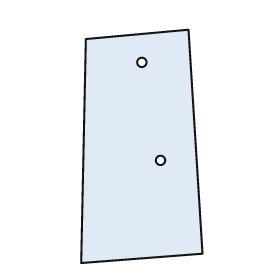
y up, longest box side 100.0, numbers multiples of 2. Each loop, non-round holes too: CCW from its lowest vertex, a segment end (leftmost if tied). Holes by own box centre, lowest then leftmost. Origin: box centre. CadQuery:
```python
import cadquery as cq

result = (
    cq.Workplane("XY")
    .moveTo(-26.0, -50.0)
    .lineTo(26.0, -46.0)
    .lineTo(20.0, 50.0)
    .lineTo(-24.0, 46.0)
    .close()
    .moveTo(8.0, -6.0)
    .circle(2.0)
    .moveTo(0.0, 36.0)
    .circle(2.0)
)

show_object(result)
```